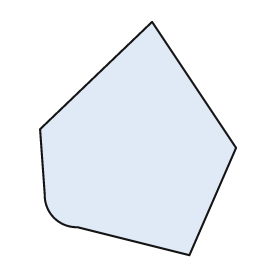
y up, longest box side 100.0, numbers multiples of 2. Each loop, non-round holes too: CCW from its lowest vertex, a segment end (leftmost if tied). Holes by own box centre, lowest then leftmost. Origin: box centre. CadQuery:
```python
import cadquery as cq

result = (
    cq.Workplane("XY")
    .moveTo(22.0, -50.0)
    .lineTo(42.0, -4.0)
    .lineTo(6.0, 50.0)
    .lineTo(-42.0, 4.0)
    .lineTo(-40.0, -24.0)
    .threePointArc((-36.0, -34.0), (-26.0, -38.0))
    .close()
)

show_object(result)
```